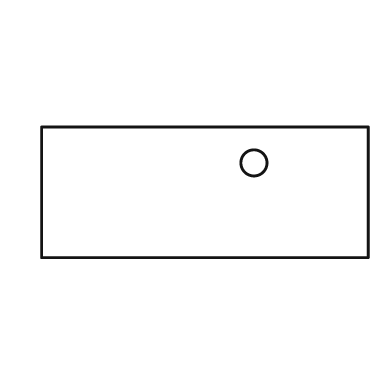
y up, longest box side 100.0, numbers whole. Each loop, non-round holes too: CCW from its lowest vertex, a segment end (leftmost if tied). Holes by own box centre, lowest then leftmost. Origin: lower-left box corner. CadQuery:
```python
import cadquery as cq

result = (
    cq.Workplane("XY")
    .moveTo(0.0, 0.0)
    .lineTo(100.0, 0.0)
    .lineTo(100.0, 40.0)
    .lineTo(0.0, 40.0)
    .close()
    .moveTo(65.0, 29.0)
    .circle(4.0)
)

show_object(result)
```